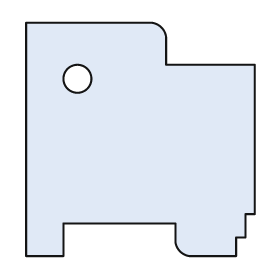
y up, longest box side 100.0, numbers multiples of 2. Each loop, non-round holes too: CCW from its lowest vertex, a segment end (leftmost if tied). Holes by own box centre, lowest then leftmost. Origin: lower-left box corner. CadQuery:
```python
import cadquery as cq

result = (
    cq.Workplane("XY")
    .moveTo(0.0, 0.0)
    .lineTo(16.0, 0.0)
    .lineTo(16.0, 14.0)
    .lineTo(64.0, 14.0)
    .lineTo(64.0, 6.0)
    .threePointArc((66.0, 2.0), (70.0, 0.0))
    .lineTo(90.0, 0.0)
    .lineTo(90.0, 8.0)
    .lineTo(94.0, 8.0)
    .lineTo(94.0, 18.0)
    .lineTo(98.0, 18.0)
    .lineTo(98.0, 82.0)
    .lineTo(60.0, 82.0)
    .lineTo(60.0, 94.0)
    .threePointArc((58.0, 98.0), (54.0, 100.0))
    .lineTo(0.0, 100.0)
    .close()
    .moveTo(22.0, 76.0)
    .circle(6.0)
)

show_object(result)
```